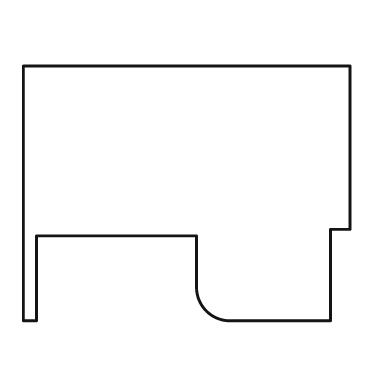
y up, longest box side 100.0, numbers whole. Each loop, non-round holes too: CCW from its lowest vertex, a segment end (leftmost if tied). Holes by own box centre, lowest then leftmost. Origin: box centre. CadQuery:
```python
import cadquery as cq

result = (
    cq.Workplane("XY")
    .moveTo(-50.0, -39.0)
    .lineTo(-46.0, -39.0)
    .lineTo(-46.0, -13.0)
    .lineTo(3.0, -13.0)
    .lineTo(3.0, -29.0)
    .threePointArc((6.0, -36.0), (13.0, -39.0))
    .lineTo(44.0, -39.0)
    .lineTo(44.0, -11.0)
    .lineTo(50.0, -11.0)
    .lineTo(50.0, 39.0)
    .lineTo(-50.0, 39.0)
    .close()
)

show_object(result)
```